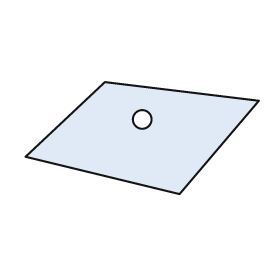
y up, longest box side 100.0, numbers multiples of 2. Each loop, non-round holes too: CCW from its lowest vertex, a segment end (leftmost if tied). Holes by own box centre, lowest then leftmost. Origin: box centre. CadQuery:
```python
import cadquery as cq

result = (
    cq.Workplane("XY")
    .moveTo(16.0, -24.0)
    .lineTo(50.0, 16.0)
    .lineTo(-16.0, 24.0)
    .lineTo(-50.0, -8.0)
    .close()
    .moveTo(0.0, 8.0)
    .circle(4.0)
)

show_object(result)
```